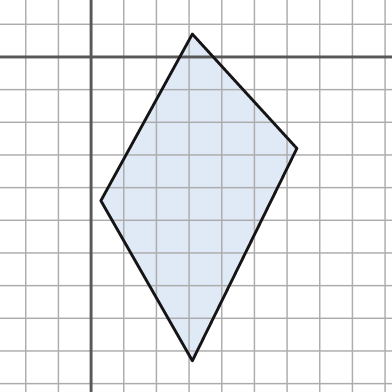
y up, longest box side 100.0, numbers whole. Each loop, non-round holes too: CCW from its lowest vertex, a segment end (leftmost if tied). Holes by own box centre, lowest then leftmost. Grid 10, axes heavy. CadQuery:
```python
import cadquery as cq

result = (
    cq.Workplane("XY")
    .moveTo(31.0, -93.0)
    .lineTo(63.0, -28.0)
    .lineTo(31.0, 7.0)
    .lineTo(3.0, -44.0)
    .close()
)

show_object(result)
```